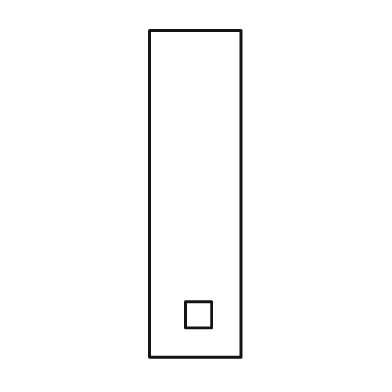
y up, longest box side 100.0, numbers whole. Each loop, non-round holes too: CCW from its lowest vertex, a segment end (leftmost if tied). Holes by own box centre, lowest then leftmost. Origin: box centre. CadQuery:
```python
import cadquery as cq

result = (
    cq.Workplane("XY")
    .moveTo(-14.0, -50.0)
    .lineTo(14.0, -50.0)
    .lineTo(14.0, 50.0)
    .lineTo(-14.0, 50.0)
    .close()
    .moveTo(-3.0, -41.0)
    .lineTo(5.0, -41.0)
    .lineTo(5.0, -33.0)
    .lineTo(-3.0, -33.0)
    .close()
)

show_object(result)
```